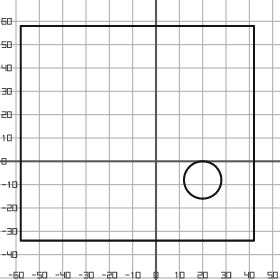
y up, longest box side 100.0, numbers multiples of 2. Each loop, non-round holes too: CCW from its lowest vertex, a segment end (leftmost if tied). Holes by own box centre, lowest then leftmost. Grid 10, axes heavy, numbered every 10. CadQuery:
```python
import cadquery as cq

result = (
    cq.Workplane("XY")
    .moveTo(-58.0, -34.0)
    .lineTo(42.0, -34.0)
    .lineTo(42.0, 58.0)
    .lineTo(-58.0, 58.0)
    .close()
    .moveTo(20.0, -8.0)
    .circle(8.0)
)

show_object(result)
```